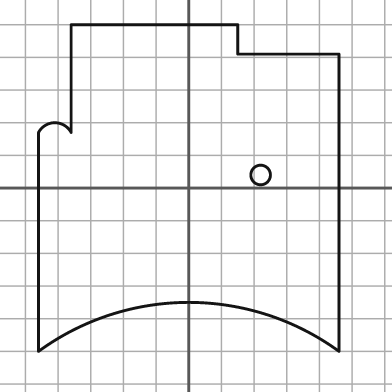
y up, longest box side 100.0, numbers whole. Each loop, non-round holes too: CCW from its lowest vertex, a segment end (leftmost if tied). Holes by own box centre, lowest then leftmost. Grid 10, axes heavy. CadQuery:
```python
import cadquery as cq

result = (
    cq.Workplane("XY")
    .moveTo(-46.0, -50.0)
    .threePointArc((0.0, -35.0), (46.0, -50.0))
    .lineTo(46.0, 41.0)
    .lineTo(15.0, 41.0)
    .lineTo(15.0, 50.0)
    .lineTo(-36.0, 50.0)
    .lineTo(-36.0, 17.0)
    .threePointArc((-41.0, 20.0), (-46.0, 17.0))
    .close()
    .moveTo(22.0, 4.0)
    .circle(3.0)
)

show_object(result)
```